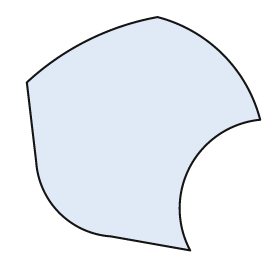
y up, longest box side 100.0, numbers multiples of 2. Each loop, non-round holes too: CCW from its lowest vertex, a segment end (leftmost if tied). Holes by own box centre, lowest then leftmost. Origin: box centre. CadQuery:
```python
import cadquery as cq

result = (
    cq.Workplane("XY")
    .moveTo(20.0, -50.0)
    .threePointArc((20.0, -14.0), (50.0, 6.0))
    .threePointArc((34.0, 34.0), (6.0, 50.0))
    .threePointArc((-24.0, 40.0), (-50.0, 22.0))
    .lineTo(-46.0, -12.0)
    .threePointArc((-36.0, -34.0), (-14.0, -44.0))
    .close()
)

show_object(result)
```